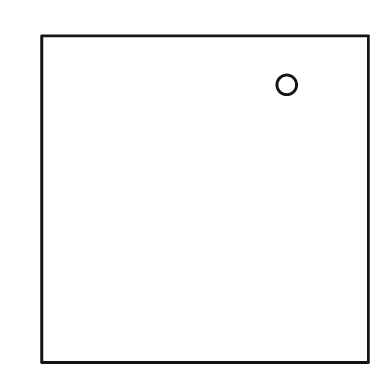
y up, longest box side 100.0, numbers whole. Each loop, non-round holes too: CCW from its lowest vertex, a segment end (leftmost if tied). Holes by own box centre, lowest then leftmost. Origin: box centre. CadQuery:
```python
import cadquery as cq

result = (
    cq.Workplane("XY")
    .moveTo(-50.0, -50.0)
    .lineTo(50.0, -50.0)
    .lineTo(50.0, 50.0)
    .lineTo(-50.0, 50.0)
    .close()
    .moveTo(25.0, 35.0)
    .circle(3.0)
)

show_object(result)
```